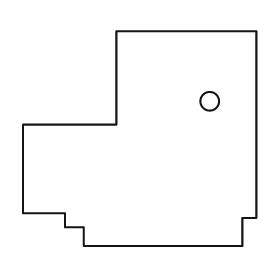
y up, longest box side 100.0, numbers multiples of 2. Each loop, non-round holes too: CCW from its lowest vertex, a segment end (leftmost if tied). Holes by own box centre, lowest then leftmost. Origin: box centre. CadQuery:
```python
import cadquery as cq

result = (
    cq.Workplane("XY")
    .moveTo(-24.0, -46.0)
    .lineTo(44.0, -46.0)
    .lineTo(44.0, -34.0)
    .lineTo(50.0, -34.0)
    .lineTo(50.0, 46.0)
    .lineTo(-10.0, 46.0)
    .lineTo(-10.0, 6.0)
    .lineTo(-50.0, 6.0)
    .lineTo(-50.0, -32.0)
    .lineTo(-32.0, -32.0)
    .lineTo(-32.0, -38.0)
    .lineTo(-24.0, -38.0)
    .close()
    .moveTo(30.0, 16.0)
    .circle(4.0)
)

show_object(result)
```